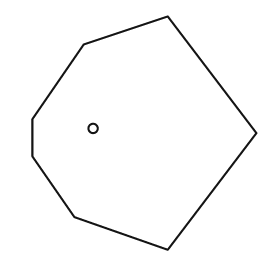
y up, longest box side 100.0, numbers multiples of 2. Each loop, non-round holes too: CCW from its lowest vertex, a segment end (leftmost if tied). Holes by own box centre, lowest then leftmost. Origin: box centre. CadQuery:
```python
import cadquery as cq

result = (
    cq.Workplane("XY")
    .moveTo(10.0, -50.0)
    .lineTo(48.0, 0.0)
    .lineTo(10.0, 50.0)
    .lineTo(-26.0, 38.0)
    .lineTo(-48.0, 6.0)
    .lineTo(-48.0, -10.0)
    .lineTo(-30.0, -36.0)
    .close()
    .moveTo(-22.0, 2.0)
    .circle(2.0)
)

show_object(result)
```